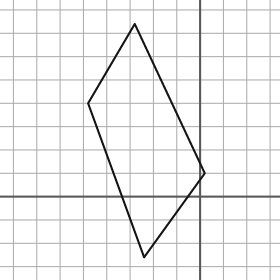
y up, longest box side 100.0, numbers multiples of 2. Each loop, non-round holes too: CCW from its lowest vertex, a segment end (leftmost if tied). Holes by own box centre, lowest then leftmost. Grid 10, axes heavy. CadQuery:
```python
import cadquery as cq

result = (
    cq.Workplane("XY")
    .moveTo(-24.0, -26.0)
    .lineTo(2.0, 10.0)
    .lineTo(-28.0, 74.0)
    .lineTo(-48.0, 40.0)
    .close()
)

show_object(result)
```